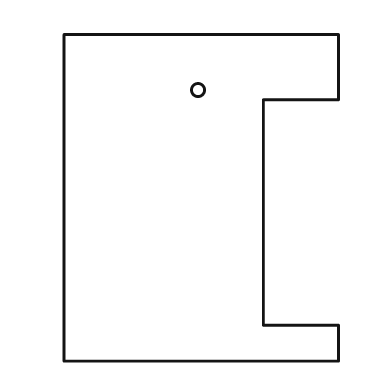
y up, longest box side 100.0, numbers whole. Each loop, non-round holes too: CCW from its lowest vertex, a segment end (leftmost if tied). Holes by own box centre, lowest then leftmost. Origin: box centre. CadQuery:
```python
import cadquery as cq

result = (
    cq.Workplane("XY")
    .moveTo(-42.0, -50.0)
    .lineTo(42.0, -50.0)
    .lineTo(42.0, -39.0)
    .lineTo(19.0, -39.0)
    .lineTo(19.0, 30.0)
    .lineTo(42.0, 30.0)
    .lineTo(42.0, 50.0)
    .lineTo(-42.0, 50.0)
    .close()
    .moveTo(-1.0, 33.0)
    .circle(2.0)
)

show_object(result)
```